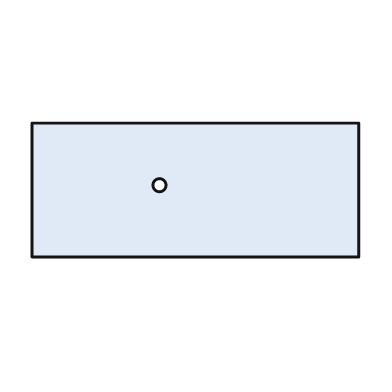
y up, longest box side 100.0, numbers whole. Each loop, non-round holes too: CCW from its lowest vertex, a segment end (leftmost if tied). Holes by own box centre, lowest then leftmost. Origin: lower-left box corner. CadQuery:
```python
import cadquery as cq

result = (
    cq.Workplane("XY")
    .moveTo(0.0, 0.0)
    .lineTo(100.0, 0.0)
    .lineTo(100.0, 41.0)
    .lineTo(0.0, 41.0)
    .close()
    .moveTo(39.0, 22.0)
    .circle(2.0)
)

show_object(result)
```